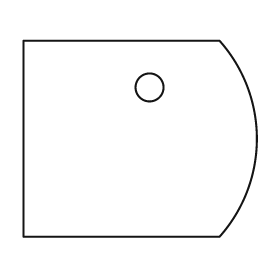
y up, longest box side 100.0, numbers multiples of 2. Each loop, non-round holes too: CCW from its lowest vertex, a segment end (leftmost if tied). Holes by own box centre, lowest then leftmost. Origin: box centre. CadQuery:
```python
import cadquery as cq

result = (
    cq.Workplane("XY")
    .moveTo(-50.0, -42.0)
    .lineTo(34.0, -42.0)
    .threePointArc((50.0, 0.0), (34.0, 42.0))
    .lineTo(-50.0, 42.0)
    .close()
    .moveTo(4.0, 22.0)
    .circle(6.0)
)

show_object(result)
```